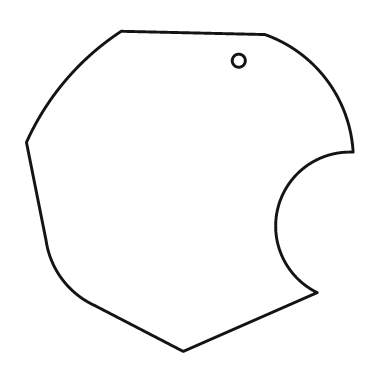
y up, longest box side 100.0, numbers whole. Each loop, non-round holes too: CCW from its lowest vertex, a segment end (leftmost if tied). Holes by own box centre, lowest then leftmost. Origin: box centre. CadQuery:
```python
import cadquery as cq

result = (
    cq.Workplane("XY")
    .moveTo(-2.0, -49.0)
    .lineTo(39.0, -31.0)
    .threePointArc((27.0, -5.0), (50.0, 12.0))
    .threePointArc((42.0, 34.0), (23.0, 48.0))
    .lineTo(-21.0, 49.0)
    .threePointArc((-38.0, 34.0), (-50.0, 15.0))
    .lineTo(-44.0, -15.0)
    .threePointArc((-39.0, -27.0), (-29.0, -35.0))
    .close()
    .moveTo(15.0, 40.0)
    .circle(2.0)
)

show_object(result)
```